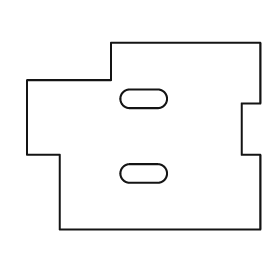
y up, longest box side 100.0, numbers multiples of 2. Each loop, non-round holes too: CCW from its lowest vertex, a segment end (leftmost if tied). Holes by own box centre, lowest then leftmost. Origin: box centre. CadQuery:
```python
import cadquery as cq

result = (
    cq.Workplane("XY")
    .moveTo(-36.0, -40.0)
    .lineTo(50.0, -40.0)
    .lineTo(50.0, -8.0)
    .lineTo(42.0, -8.0)
    .lineTo(42.0, 14.0)
    .lineTo(50.0, 14.0)
    .lineTo(50.0, 40.0)
    .lineTo(-14.0, 40.0)
    .lineTo(-14.0, 24.0)
    .lineTo(-50.0, 24.0)
    .lineTo(-50.0, -8.0)
    .lineTo(-36.0, -8.0)
    .close()
    .moveTo(-6.0, -20.0)
    .lineTo(6.0, -20.0)
    .threePointArc((10.0, -16.0), (6.0, -12.0))
    .lineTo(-6.0, -12.0)
    .threePointArc((-10.0, -16.0), (-6.0, -20.0))
    .close()
    .moveTo(-6.0, 12.0)
    .lineTo(6.0, 12.0)
    .threePointArc((10.0, 16.0), (6.0, 20.0))
    .lineTo(-6.0, 20.0)
    .threePointArc((-10.0, 16.0), (-6.0, 12.0))
    .close()
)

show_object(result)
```